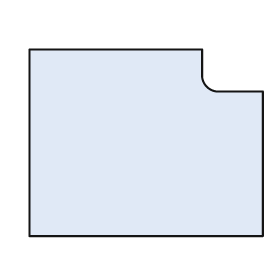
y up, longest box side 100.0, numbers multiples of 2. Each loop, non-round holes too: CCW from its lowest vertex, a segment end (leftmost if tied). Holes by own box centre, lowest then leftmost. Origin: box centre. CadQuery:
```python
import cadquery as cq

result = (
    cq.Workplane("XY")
    .moveTo(-50.0, -40.0)
    .lineTo(50.0, -40.0)
    .lineTo(50.0, 22.0)
    .lineTo(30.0, 22.0)
    .threePointArc((26.0, 24.0), (24.0, 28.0))
    .lineTo(24.0, 40.0)
    .lineTo(-50.0, 40.0)
    .close()
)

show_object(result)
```